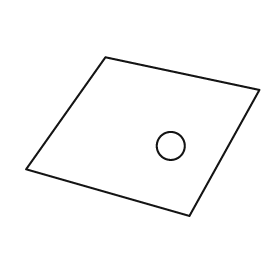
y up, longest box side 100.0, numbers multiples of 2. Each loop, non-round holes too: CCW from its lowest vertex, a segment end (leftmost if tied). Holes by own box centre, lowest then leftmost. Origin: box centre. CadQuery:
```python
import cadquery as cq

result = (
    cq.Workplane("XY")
    .moveTo(20.0, -34.0)
    .lineTo(50.0, 20.0)
    .lineTo(-16.0, 34.0)
    .lineTo(-50.0, -14.0)
    .close()
    .moveTo(12.0, -4.0)
    .circle(6.0)
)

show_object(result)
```